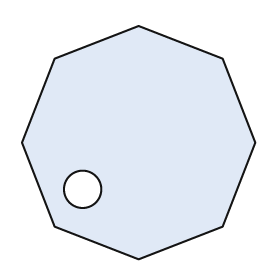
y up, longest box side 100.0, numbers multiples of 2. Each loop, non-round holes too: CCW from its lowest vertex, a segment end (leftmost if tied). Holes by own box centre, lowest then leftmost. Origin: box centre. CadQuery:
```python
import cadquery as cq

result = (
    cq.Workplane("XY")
    .moveTo(0.0, -50.0)
    .lineTo(36.0, -36.0)
    .lineTo(50.0, 0.0)
    .lineTo(36.0, 36.0)
    .lineTo(0.0, 50.0)
    .lineTo(-36.0, 36.0)
    .lineTo(-50.0, 0.0)
    .lineTo(-36.0, -36.0)
    .close()
    .moveTo(-24.0, -20.0)
    .circle(8.0)
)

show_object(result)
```